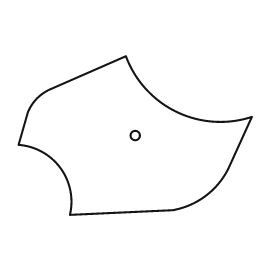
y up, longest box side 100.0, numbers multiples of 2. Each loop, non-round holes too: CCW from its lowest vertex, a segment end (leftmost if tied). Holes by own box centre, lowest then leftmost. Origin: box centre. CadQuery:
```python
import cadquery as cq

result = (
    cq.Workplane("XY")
    .moveTo(-28.0, -34.0)
    .lineTo(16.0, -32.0)
    .threePointArc((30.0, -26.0), (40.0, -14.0))
    .lineTo(50.0, 8.0)
    .threePointArc((18.0, 10.0), (-4.0, 34.0))
    .lineTo(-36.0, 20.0)
    .threePointArc((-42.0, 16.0), (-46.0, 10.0))
    .lineTo(-50.0, -4.0)
    .threePointArc((-32.0, -14.0), (-28.0, -34.0))
    .close()
    .moveTo(0.0, 0.0)
    .circle(2.0)
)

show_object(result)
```